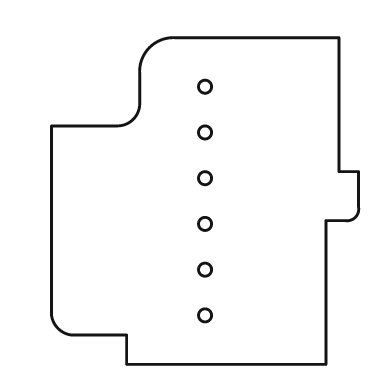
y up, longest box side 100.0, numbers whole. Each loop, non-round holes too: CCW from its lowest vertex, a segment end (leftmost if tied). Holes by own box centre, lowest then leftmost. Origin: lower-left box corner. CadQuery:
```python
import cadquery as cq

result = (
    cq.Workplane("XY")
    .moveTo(23.0, 0.0)
    .lineTo(84.0, 0.0)
    .lineTo(84.0, 44.0)
    .lineTo(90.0, 44.0)
    .threePointArc((93.0, 45.0), (94.0, 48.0))
    .lineTo(94.0, 59.0)
    .lineTo(88.0, 59.0)
    .lineTo(88.0, 100.0)
    .lineTo(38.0, 100.0)
    .threePointArc((30.0, 97.0), (27.0, 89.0))
    .lineTo(27.0, 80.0)
    .threePointArc((25.0, 75.0), (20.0, 73.0))
    .lineTo(0.0, 73.0)
    .lineTo(0.0, 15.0)
    .threePointArc((2.0, 11.0), (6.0, 9.0))
    .lineTo(23.0, 9.0)
    .close()
    .moveTo(47.0, 15.0)
    .circle(2.0)
    .moveTo(47.0, 29.0)
    .circle(2.0)
    .moveTo(47.0, 43.0)
    .circle(2.0)
    .moveTo(47.0, 57.0)
    .circle(2.0)
    .moveTo(47.0, 71.0)
    .circle(2.0)
    .moveTo(47.0, 85.0)
    .circle(2.0)
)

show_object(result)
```